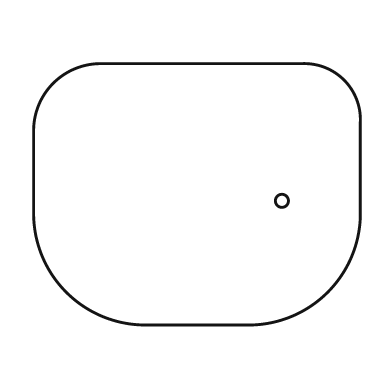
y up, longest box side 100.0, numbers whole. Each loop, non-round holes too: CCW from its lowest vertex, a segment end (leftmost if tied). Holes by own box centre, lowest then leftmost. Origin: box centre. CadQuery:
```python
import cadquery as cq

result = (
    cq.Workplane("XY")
    .moveTo(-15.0, -40.0)
    .lineTo(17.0, -40.0)
    .threePointArc((40.0, -30.0), (50.0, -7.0))
    .lineTo(50.0, 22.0)
    .threePointArc((45.0, 35.0), (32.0, 40.0))
    .lineTo(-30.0, 40.0)
    .threePointArc((-44.0, 34.0), (-50.0, 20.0))
    .lineTo(-50.0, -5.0)
    .threePointArc((-40.0, -30.0), (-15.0, -40.0))
    .close()
    .moveTo(26.0, -2.0)
    .circle(2.0)
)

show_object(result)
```